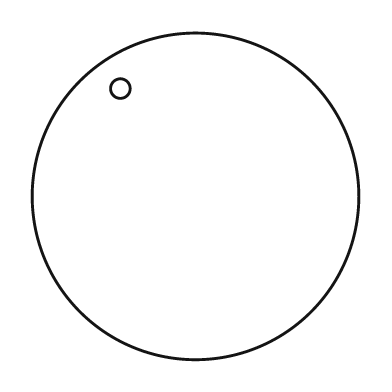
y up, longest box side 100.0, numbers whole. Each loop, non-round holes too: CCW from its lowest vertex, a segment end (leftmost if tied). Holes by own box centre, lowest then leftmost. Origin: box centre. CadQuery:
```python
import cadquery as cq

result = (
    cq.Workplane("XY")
    .moveTo(0.0, 0.0)
    .circle(50.0)
    .moveTo(-23.0, 33.0)
    .circle(3.0)
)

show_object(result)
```